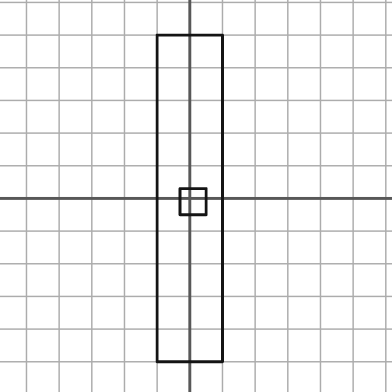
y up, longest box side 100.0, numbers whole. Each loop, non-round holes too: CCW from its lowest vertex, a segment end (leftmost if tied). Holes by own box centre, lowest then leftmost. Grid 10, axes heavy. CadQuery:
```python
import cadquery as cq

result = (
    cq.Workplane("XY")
    .moveTo(-10.0, -50.0)
    .lineTo(10.0, -50.0)
    .lineTo(10.0, 50.0)
    .lineTo(-10.0, 50.0)
    .close()
    .moveTo(-3.0, -5.0)
    .lineTo(5.0, -5.0)
    .lineTo(5.0, 3.0)
    .lineTo(-3.0, 3.0)
    .close()
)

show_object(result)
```